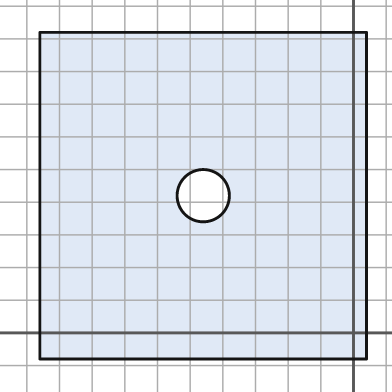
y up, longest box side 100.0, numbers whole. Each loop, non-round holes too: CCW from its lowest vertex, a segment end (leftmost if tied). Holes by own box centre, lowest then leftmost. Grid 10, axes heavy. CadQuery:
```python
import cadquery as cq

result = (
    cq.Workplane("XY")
    .moveTo(-96.0, -8.0)
    .lineTo(4.0, -8.0)
    .lineTo(4.0, 92.0)
    .lineTo(-96.0, 92.0)
    .close()
    .moveTo(-46.0, 42.0)
    .circle(8.0)
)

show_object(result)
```